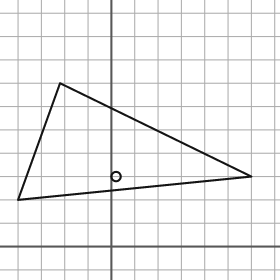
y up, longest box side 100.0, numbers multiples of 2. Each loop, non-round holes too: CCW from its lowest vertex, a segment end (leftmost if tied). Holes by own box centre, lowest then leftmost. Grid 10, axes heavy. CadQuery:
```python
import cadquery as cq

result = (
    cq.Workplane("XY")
    .moveTo(-40.0, 20.0)
    .lineTo(60.0, 30.0)
    .lineTo(-22.0, 70.0)
    .close()
    .moveTo(2.0, 30.0)
    .circle(2.0)
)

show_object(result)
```